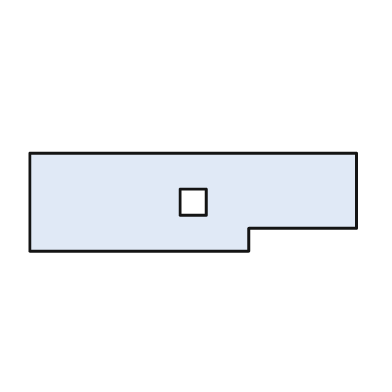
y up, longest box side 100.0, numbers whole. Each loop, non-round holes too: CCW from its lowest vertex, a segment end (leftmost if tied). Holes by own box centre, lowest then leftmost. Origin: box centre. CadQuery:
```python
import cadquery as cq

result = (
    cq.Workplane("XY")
    .moveTo(-50.0, -15.0)
    .lineTo(17.0, -15.0)
    .lineTo(17.0, -8.0)
    .lineTo(50.0, -8.0)
    .lineTo(50.0, 15.0)
    .lineTo(-50.0, 15.0)
    .close()
    .moveTo(-4.0, -4.0)
    .lineTo(4.0, -4.0)
    .lineTo(4.0, 4.0)
    .lineTo(-4.0, 4.0)
    .close()
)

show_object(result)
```